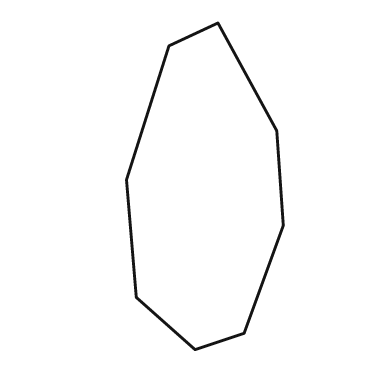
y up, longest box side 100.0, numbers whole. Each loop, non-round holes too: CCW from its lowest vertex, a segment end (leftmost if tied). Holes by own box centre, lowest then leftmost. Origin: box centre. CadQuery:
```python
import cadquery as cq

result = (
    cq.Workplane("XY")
    .moveTo(-3.0, -50.0)
    .lineTo(12.0, -45.0)
    .lineTo(24.0, -12.0)
    .lineTo(22.0, 17.0)
    .lineTo(4.0, 50.0)
    .lineTo(-11.0, 43.0)
    .lineTo(-24.0, 2.0)
    .lineTo(-21.0, -34.0)
    .close()
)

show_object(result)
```